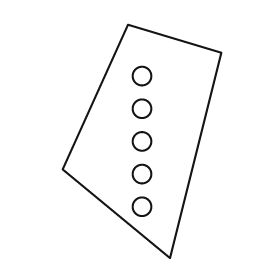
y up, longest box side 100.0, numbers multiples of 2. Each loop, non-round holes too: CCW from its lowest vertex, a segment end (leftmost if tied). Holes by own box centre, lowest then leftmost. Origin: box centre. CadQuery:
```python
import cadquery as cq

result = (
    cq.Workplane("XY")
    .moveTo(12.0, -50.0)
    .lineTo(34.0, 38.0)
    .lineTo(-6.0, 50.0)
    .lineTo(-34.0, -12.0)
    .close()
    .moveTo(0.0, -28.0)
    .circle(4.0)
    .moveTo(0.0, -14.0)
    .circle(4.0)
    .moveTo(0.0, 0.0)
    .circle(4.0)
    .moveTo(0.0, 14.0)
    .circle(4.0)
    .moveTo(0.0, 28.0)
    .circle(4.0)
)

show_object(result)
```